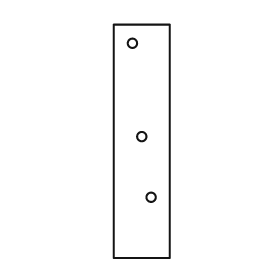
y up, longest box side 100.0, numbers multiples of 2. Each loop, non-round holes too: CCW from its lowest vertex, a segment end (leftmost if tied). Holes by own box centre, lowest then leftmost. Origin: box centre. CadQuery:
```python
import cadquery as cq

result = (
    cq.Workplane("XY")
    .moveTo(-12.0, -50.0)
    .lineTo(12.0, -50.0)
    .lineTo(12.0, 50.0)
    .lineTo(-12.0, 50.0)
    .close()
    .moveTo(4.0, -24.0)
    .circle(2.0)
    .moveTo(0.0, 2.0)
    .circle(2.0)
    .moveTo(-4.0, 42.0)
    .circle(2.0)
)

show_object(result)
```